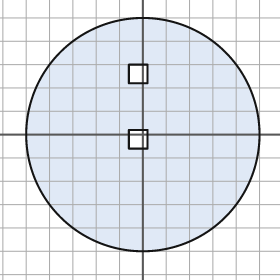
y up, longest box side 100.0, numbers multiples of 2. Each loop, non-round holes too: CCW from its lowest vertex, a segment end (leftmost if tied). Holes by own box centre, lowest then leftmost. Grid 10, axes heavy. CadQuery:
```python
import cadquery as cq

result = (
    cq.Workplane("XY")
    .moveTo(0.0, 0.0)
    .circle(50.0)
    .moveTo(-6.0, -6.0)
    .lineTo(2.0, -6.0)
    .lineTo(2.0, 2.0)
    .lineTo(-6.0, 2.0)
    .close()
    .moveTo(-6.0, 22.0)
    .lineTo(2.0, 22.0)
    .lineTo(2.0, 30.0)
    .lineTo(-6.0, 30.0)
    .close()
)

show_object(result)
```